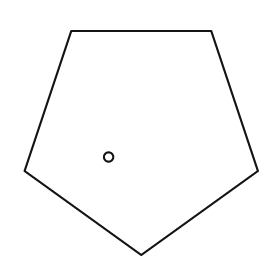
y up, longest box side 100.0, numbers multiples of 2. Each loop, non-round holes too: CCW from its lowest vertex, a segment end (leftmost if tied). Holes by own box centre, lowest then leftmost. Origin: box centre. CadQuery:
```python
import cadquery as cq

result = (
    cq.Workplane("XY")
    .moveTo(0.0, -48.0)
    .lineTo(50.0, -12.0)
    .lineTo(30.0, 48.0)
    .lineTo(-30.0, 48.0)
    .lineTo(-50.0, -12.0)
    .close()
    .moveTo(-14.0, -6.0)
    .circle(2.0)
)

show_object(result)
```